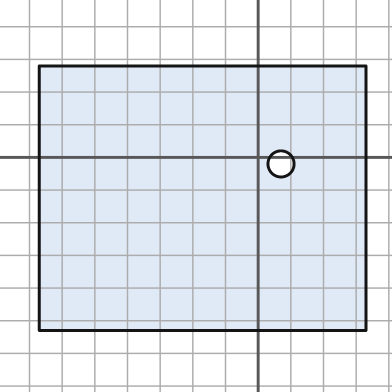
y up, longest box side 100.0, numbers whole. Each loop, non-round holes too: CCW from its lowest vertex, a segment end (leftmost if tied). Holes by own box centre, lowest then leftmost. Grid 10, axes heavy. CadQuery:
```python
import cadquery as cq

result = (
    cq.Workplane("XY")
    .moveTo(-67.0, -53.0)
    .lineTo(33.0, -53.0)
    .lineTo(33.0, 28.0)
    .lineTo(-67.0, 28.0)
    .close()
    .moveTo(7.0, -2.0)
    .circle(4.0)
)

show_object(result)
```